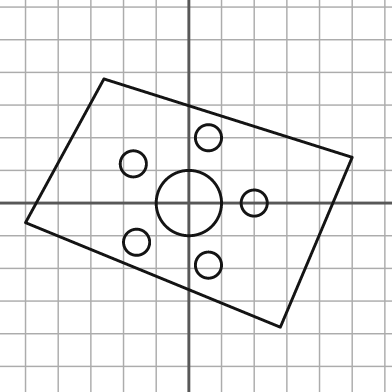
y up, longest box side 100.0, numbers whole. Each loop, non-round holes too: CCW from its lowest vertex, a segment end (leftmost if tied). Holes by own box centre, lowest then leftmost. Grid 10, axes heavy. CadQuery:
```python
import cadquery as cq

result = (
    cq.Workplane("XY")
    .moveTo(28.0, -38.0)
    .lineTo(50.0, 14.0)
    .lineTo(-26.0, 38.0)
    .lineTo(-50.0, -6.0)
    .close()
    .moveTo(6.0, -19.0)
    .circle(4.0)
    .moveTo(-16.0, -12.0)
    .circle(4.0)
    .moveTo(0.0, 0.0)
    .circle(10.0)
    .moveTo(20.0, 0.0)
    .circle(4.0)
    .moveTo(-17.0, 12.0)
    .circle(4.0)
    .moveTo(6.0, 20.0)
    .circle(4.0)
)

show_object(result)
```